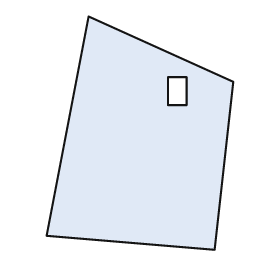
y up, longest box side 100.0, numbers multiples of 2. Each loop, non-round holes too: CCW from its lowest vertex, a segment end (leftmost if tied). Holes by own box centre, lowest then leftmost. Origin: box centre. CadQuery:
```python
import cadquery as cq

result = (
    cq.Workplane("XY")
    .moveTo(32.0, -50.0)
    .lineTo(40.0, 22.0)
    .lineTo(-22.0, 50.0)
    .lineTo(-40.0, -44.0)
    .close()
    .moveTo(12.0, 12.0)
    .lineTo(20.0, 12.0)
    .lineTo(20.0, 24.0)
    .lineTo(12.0, 24.0)
    .close()
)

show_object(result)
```